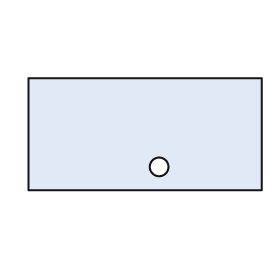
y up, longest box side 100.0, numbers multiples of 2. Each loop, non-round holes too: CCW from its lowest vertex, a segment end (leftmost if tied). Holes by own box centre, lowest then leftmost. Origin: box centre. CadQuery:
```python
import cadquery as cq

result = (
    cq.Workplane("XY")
    .moveTo(-50.0, -24.0)
    .lineTo(50.0, -24.0)
    .lineTo(50.0, 24.0)
    .lineTo(-50.0, 24.0)
    .close()
    .moveTo(6.0, -14.0)
    .circle(4.0)
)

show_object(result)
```